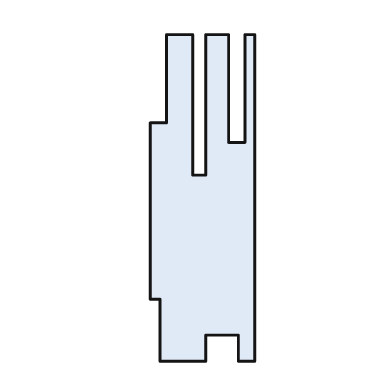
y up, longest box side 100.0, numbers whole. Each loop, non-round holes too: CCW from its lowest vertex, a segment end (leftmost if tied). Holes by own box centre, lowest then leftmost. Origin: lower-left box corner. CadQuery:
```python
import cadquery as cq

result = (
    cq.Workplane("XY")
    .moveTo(3.0, 0.0)
    .lineTo(17.0, 0.0)
    .lineTo(17.0, 8.0)
    .lineTo(27.0, 8.0)
    .lineTo(27.0, 0.0)
    .lineTo(32.0, 0.0)
    .lineTo(32.0, 100.0)
    .lineTo(29.0, 100.0)
    .lineTo(29.0, 67.0)
    .lineTo(24.0, 67.0)
    .lineTo(24.0, 100.0)
    .lineTo(17.0, 100.0)
    .lineTo(17.0, 57.0)
    .lineTo(13.0, 57.0)
    .lineTo(13.0, 100.0)
    .lineTo(5.0, 100.0)
    .lineTo(5.0, 73.0)
    .lineTo(0.0, 73.0)
    .lineTo(0.0, 19.0)
    .lineTo(3.0, 19.0)
    .close()
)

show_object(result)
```